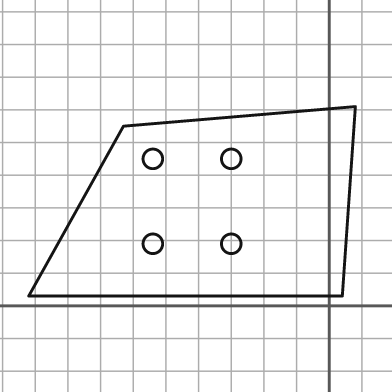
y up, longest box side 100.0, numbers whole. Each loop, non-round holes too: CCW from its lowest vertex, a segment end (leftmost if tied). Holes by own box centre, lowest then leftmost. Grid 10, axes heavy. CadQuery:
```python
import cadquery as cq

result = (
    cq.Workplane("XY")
    .moveTo(-92.0, 3.0)
    .lineTo(4.0, 3.0)
    .lineTo(8.0, 61.0)
    .lineTo(-63.0, 55.0)
    .close()
    .moveTo(-54.0, 19.0)
    .circle(3.0)
    .moveTo(-30.0, 19.0)
    .circle(3.0)
    .moveTo(-54.0, 45.0)
    .circle(3.0)
    .moveTo(-30.0, 45.0)
    .circle(3.0)
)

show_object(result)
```